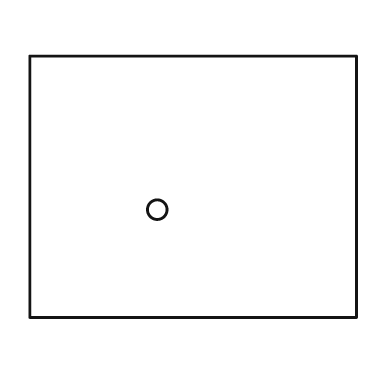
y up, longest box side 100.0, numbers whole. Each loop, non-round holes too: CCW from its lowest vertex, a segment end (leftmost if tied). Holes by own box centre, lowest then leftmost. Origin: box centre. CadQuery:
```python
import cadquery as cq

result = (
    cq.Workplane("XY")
    .moveTo(-50.0, -40.0)
    .lineTo(50.0, -40.0)
    .lineTo(50.0, 40.0)
    .lineTo(-50.0, 40.0)
    .close()
    .moveTo(-11.0, -7.0)
    .circle(3.0)
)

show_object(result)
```